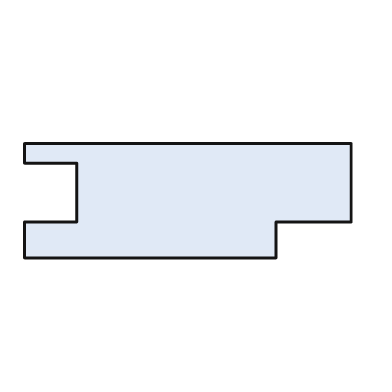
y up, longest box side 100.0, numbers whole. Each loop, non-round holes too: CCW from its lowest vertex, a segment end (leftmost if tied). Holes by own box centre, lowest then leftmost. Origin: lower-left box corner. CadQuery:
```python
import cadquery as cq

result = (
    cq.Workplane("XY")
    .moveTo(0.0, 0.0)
    .lineTo(77.0, 0.0)
    .lineTo(77.0, 11.0)
    .lineTo(100.0, 11.0)
    .lineTo(100.0, 35.0)
    .lineTo(0.0, 35.0)
    .lineTo(0.0, 29.0)
    .lineTo(16.0, 29.0)
    .lineTo(16.0, 11.0)
    .lineTo(0.0, 11.0)
    .close()
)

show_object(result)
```